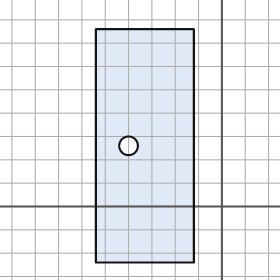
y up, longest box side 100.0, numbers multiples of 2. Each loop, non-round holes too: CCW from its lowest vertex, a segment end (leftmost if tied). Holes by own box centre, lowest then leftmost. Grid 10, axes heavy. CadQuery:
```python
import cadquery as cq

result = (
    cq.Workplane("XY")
    .moveTo(-54.0, -24.0)
    .lineTo(-12.0, -24.0)
    .lineTo(-12.0, 76.0)
    .lineTo(-54.0, 76.0)
    .close()
    .moveTo(-40.0, 26.0)
    .circle(4.0)
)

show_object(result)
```